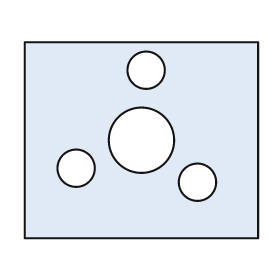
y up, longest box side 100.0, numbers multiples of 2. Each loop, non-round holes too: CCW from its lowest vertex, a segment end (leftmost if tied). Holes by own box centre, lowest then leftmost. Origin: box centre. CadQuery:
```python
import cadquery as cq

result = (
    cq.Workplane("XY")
    .moveTo(-50.0, -42.0)
    .lineTo(50.0, -42.0)
    .lineTo(50.0, 42.0)
    .lineTo(-50.0, 42.0)
    .close()
    .moveTo(24.0, -18.0)
    .circle(8.0)
    .moveTo(-28.0, -12.0)
    .circle(8.0)
    .moveTo(0.0, 0.0)
    .circle(14.0)
    .moveTo(2.0, 30.0)
    .circle(8.0)
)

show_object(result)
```